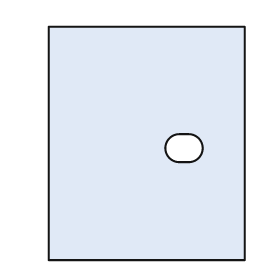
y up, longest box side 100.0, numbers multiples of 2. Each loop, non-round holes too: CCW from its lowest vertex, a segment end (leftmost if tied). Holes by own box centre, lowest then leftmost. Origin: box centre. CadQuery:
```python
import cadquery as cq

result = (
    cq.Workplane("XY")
    .moveTo(-42.0, -50.0)
    .lineTo(42.0, -50.0)
    .lineTo(42.0, 50.0)
    .lineTo(-42.0, 50.0)
    .close()
    .moveTo(14.0, -8.0)
    .lineTo(18.0, -8.0)
    .threePointArc((24.0, -2.0), (18.0, 4.0))
    .lineTo(14.0, 4.0)
    .threePointArc((8.0, -2.0), (14.0, -8.0))
    .close()
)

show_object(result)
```